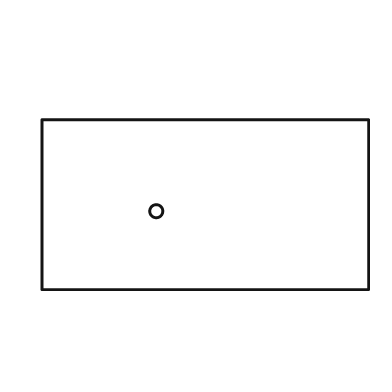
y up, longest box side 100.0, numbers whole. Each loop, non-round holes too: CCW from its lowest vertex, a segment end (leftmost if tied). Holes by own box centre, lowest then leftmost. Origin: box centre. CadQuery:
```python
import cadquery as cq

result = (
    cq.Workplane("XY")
    .moveTo(-50.0, -26.0)
    .lineTo(50.0, -26.0)
    .lineTo(50.0, 26.0)
    .lineTo(-50.0, 26.0)
    .close()
    .moveTo(-15.0, -2.0)
    .circle(2.0)
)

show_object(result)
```